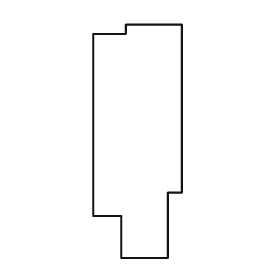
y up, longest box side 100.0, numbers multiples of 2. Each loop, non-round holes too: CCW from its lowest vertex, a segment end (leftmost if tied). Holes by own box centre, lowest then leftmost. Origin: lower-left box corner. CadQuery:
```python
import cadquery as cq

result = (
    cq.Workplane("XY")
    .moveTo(12.0, 0.0)
    .lineTo(32.0, 0.0)
    .lineTo(32.0, 28.0)
    .lineTo(38.0, 28.0)
    .lineTo(38.0, 100.0)
    .lineTo(14.0, 100.0)
    .lineTo(14.0, 96.0)
    .lineTo(0.0, 96.0)
    .lineTo(0.0, 18.0)
    .lineTo(12.0, 18.0)
    .close()
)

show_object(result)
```